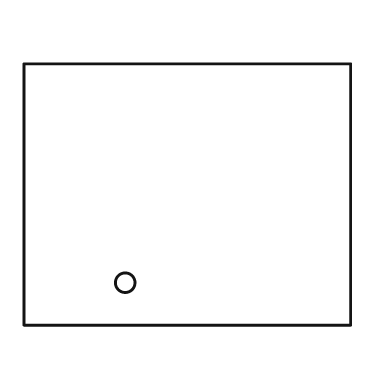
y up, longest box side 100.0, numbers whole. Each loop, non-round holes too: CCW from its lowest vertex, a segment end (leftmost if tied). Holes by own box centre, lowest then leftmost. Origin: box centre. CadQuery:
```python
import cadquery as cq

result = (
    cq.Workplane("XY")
    .moveTo(-50.0, -40.0)
    .lineTo(50.0, -40.0)
    .lineTo(50.0, 40.0)
    .lineTo(-50.0, 40.0)
    .close()
    .moveTo(-19.0, -27.0)
    .circle(3.0)
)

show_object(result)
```